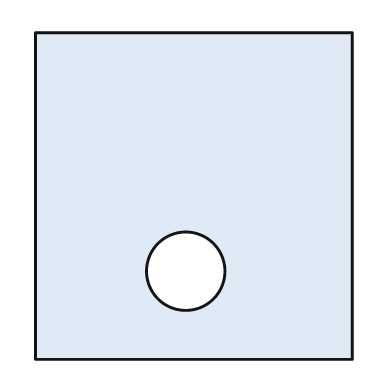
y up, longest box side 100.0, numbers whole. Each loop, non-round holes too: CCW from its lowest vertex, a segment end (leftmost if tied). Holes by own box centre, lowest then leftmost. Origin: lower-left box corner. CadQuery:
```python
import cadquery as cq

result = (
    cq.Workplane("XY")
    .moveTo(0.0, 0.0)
    .lineTo(97.0, 0.0)
    .lineTo(97.0, 100.0)
    .lineTo(0.0, 100.0)
    .close()
    .moveTo(46.0, 27.0)
    .circle(12.0)
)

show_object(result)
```